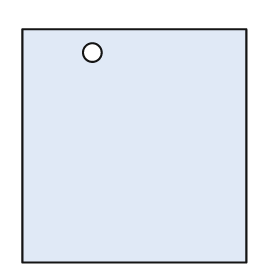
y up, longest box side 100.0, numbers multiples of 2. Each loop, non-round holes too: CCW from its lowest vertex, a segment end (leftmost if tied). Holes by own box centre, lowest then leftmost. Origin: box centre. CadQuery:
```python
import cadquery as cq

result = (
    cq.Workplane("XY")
    .moveTo(-48.0, -50.0)
    .lineTo(48.0, -50.0)
    .lineTo(48.0, 50.0)
    .lineTo(-48.0, 50.0)
    .close()
    .moveTo(-18.0, 40.0)
    .circle(4.0)
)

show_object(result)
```